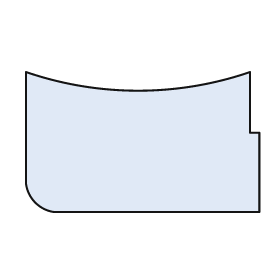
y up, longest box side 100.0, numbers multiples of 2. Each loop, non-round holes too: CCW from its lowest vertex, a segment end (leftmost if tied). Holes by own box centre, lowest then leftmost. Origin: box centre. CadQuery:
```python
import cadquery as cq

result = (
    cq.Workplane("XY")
    .moveTo(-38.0, -30.0)
    .lineTo(50.0, -30.0)
    .lineTo(50.0, 4.0)
    .lineTo(46.0, 4.0)
    .lineTo(46.0, 30.0)
    .threePointArc((-2.0, 22.0), (-50.0, 30.0))
    .lineTo(-50.0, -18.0)
    .threePointArc((-46.0, -26.0), (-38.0, -30.0))
    .close()
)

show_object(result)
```